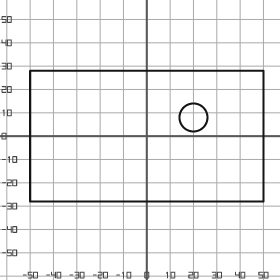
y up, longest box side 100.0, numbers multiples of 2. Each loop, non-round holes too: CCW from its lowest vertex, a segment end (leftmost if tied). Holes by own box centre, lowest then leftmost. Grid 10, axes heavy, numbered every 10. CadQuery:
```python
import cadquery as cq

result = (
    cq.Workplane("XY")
    .moveTo(-50.0, -28.0)
    .lineTo(50.0, -28.0)
    .lineTo(50.0, 28.0)
    .lineTo(-50.0, 28.0)
    .close()
    .moveTo(20.0, 8.0)
    .circle(6.0)
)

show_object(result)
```